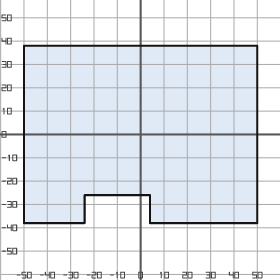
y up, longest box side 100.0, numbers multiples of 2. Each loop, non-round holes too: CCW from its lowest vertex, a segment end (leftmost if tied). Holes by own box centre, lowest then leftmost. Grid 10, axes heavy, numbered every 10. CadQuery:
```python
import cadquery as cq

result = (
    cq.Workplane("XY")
    .moveTo(-50.0, -38.0)
    .lineTo(-24.0, -38.0)
    .lineTo(-24.0, -26.0)
    .lineTo(4.0, -26.0)
    .lineTo(4.0, -38.0)
    .lineTo(50.0, -38.0)
    .lineTo(50.0, 38.0)
    .lineTo(-50.0, 38.0)
    .close()
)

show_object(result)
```